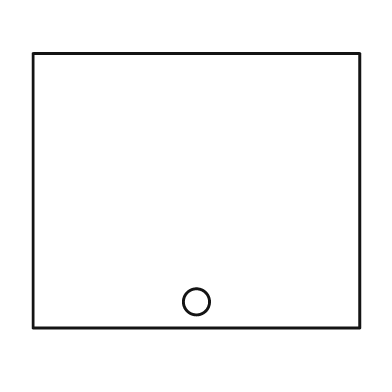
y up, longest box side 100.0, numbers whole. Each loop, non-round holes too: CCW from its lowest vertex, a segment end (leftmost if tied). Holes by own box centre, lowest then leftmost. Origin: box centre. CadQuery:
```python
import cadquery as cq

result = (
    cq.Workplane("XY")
    .moveTo(-50.0, -42.0)
    .lineTo(50.0, -42.0)
    .lineTo(50.0, 42.0)
    .lineTo(-50.0, 42.0)
    .close()
    .moveTo(0.0, -34.0)
    .circle(4.0)
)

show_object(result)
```